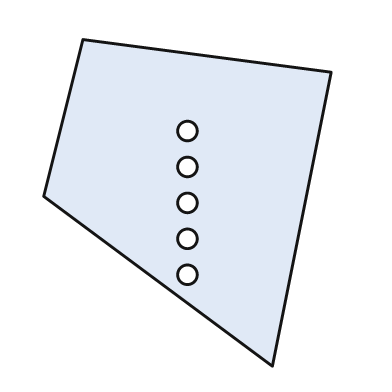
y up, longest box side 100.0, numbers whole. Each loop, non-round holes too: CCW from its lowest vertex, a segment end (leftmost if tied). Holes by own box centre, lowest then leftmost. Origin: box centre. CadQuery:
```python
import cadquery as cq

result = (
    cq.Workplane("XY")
    .moveTo(26.0, -50.0)
    .lineTo(44.0, 40.0)
    .lineTo(-32.0, 50.0)
    .lineTo(-44.0, 2.0)
    .close()
    .moveTo(0.0, -22.0)
    .circle(3.0)
    .moveTo(0.0, -11.0)
    .circle(3.0)
    .moveTo(0.0, 0.0)
    .circle(3.0)
    .moveTo(0.0, 11.0)
    .circle(3.0)
    .moveTo(0.0, 22.0)
    .circle(3.0)
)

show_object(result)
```